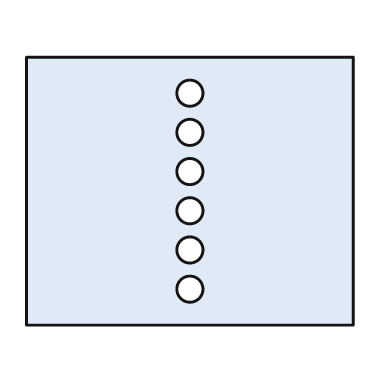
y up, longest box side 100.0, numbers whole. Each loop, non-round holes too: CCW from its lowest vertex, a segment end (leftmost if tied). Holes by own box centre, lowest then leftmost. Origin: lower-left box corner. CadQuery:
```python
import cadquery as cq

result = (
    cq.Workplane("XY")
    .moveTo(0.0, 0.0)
    .lineTo(100.0, 0.0)
    .lineTo(100.0, 82.0)
    .lineTo(0.0, 82.0)
    .close()
    .moveTo(50.0, 11.0)
    .circle(4.0)
    .moveTo(50.0, 23.0)
    .circle(4.0)
    .moveTo(50.0, 35.0)
    .circle(4.0)
    .moveTo(50.0, 47.0)
    .circle(4.0)
    .moveTo(50.0, 59.0)
    .circle(4.0)
    .moveTo(50.0, 71.0)
    .circle(4.0)
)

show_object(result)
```